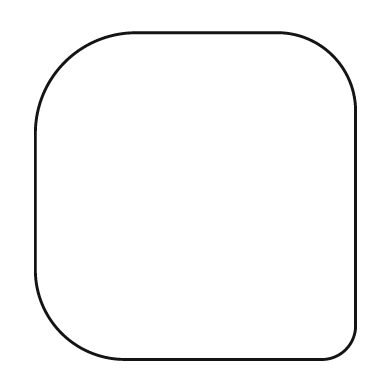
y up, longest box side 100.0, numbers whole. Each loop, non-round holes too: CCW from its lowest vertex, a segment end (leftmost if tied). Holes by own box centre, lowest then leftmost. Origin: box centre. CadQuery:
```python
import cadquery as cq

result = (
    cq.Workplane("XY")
    .moveTo(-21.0, -50.0)
    .lineTo(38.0, -50.0)
    .threePointArc((46.0, -47.0), (49.0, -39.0))
    .lineTo(49.0, 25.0)
    .threePointArc((42.0, 43.0), (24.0, 50.0))
    .lineTo(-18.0, 50.0)
    .threePointArc((-40.0, 41.0), (-49.0, 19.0))
    .lineTo(-49.0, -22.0)
    .threePointArc((-41.0, -42.0), (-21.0, -50.0))
    .close()
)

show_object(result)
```